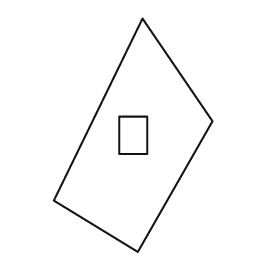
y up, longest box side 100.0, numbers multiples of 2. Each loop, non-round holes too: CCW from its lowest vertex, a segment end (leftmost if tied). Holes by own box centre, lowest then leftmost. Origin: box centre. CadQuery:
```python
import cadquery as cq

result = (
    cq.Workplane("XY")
    .moveTo(2.0, -50.0)
    .lineTo(34.0, 6.0)
    .lineTo(4.0, 50.0)
    .lineTo(-34.0, -28.0)
    .close()
    .moveTo(-6.0, -8.0)
    .lineTo(6.0, -8.0)
    .lineTo(6.0, 8.0)
    .lineTo(-6.0, 8.0)
    .close()
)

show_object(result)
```